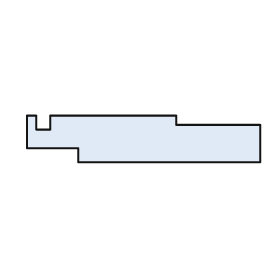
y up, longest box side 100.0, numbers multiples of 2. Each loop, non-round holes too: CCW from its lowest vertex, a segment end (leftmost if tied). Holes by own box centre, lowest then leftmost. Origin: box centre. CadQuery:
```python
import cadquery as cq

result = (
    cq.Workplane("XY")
    .moveTo(-28.0, -10.0)
    .lineTo(50.0, -10.0)
    .lineTo(50.0, 6.0)
    .lineTo(14.0, 6.0)
    .lineTo(14.0, 10.0)
    .lineTo(-40.0, 10.0)
    .lineTo(-40.0, 4.0)
    .lineTo(-46.0, 4.0)
    .lineTo(-46.0, 10.0)
    .lineTo(-50.0, 10.0)
    .lineTo(-50.0, -4.0)
    .lineTo(-28.0, -4.0)
    .close()
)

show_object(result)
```